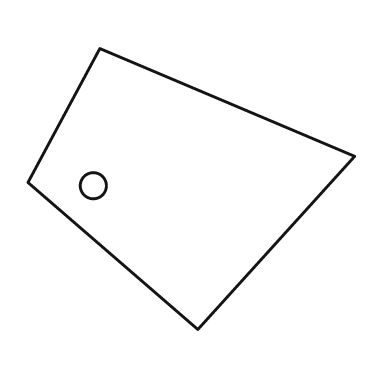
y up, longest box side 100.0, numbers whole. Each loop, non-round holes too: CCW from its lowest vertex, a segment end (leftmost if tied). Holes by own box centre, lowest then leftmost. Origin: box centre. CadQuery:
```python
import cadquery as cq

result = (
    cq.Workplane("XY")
    .moveTo(2.0, -43.0)
    .lineTo(50.0, 10.0)
    .lineTo(-28.0, 43.0)
    .lineTo(-50.0, 2.0)
    .close()
    .moveTo(-30.0, 1.0)
    .circle(4.0)
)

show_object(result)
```